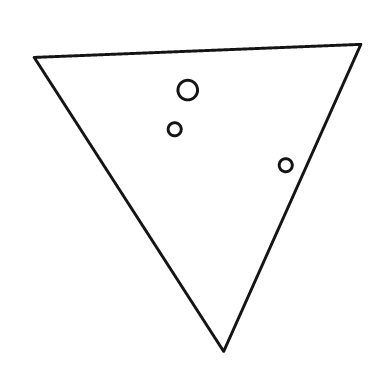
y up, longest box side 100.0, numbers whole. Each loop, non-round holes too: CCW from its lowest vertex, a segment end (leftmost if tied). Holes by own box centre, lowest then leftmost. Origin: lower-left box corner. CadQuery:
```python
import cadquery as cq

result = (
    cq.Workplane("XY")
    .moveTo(58.0, 0.0)
    .lineTo(100.0, 94.0)
    .lineTo(0.0, 90.0)
    .close()
    .moveTo(77.0, 57.0)
    .circle(2.0)
    .moveTo(43.0, 68.0)
    .circle(2.0)
    .moveTo(47.0, 80.0)
    .circle(3.0)
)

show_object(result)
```